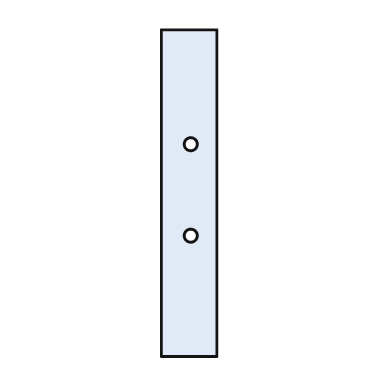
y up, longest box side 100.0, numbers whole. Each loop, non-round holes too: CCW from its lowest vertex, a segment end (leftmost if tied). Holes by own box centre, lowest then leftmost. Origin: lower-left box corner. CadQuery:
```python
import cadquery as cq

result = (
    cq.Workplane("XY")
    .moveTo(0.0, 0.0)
    .lineTo(17.0, 0.0)
    .lineTo(17.0, 100.0)
    .lineTo(0.0, 100.0)
    .close()
    .moveTo(9.0, 37.0)
    .circle(2.0)
    .moveTo(9.0, 65.0)
    .circle(2.0)
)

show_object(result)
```